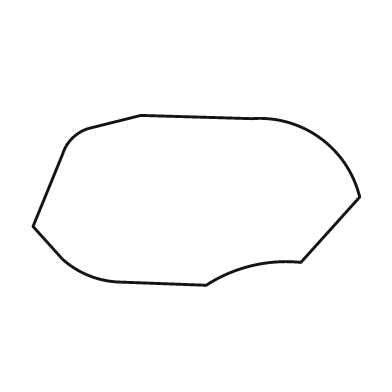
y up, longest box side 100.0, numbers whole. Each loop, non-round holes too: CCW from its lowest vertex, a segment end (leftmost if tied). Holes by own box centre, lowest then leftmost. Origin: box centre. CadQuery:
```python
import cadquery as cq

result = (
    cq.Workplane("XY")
    .moveTo(3.0, -26.0)
    .threePointArc((17.0, -20.0), (32.0, -19.0))
    .lineTo(50.0, 1.0)
    .threePointArc((38.0, 19.0), (17.0, 25.0))
    .lineTo(-17.0, 26.0)
    .lineTo(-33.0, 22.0)
    .threePointArc((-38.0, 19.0), (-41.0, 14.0))
    .lineTo(-50.0, -8.0)
    .lineTo(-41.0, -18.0)
    .threePointArc((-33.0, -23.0), (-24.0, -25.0))
    .close()
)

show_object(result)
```